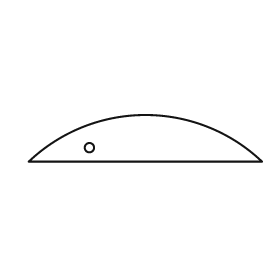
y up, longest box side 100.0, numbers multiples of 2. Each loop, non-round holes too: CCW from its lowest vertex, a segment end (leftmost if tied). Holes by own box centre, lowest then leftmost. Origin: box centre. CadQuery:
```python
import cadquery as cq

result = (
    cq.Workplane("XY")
    .moveTo(-50.0, -10.0)
    .lineTo(50.0, -10.0)
    .threePointArc((0.0, 10.0), (-50.0, -10.0))
    .close()
    .moveTo(-24.0, -4.0)
    .circle(2.0)
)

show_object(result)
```